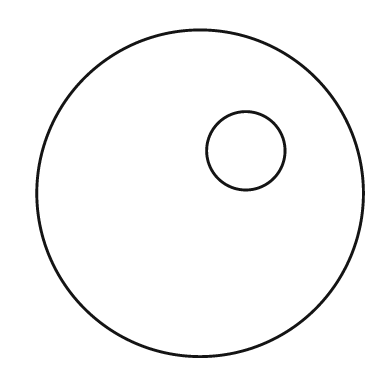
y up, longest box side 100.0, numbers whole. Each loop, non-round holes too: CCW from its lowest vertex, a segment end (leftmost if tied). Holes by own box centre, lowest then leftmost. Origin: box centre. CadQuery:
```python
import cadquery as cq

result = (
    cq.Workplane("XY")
    .moveTo(0.0, 0.0)
    .circle(50.0)
    .moveTo(14.0, 13.0)
    .circle(12.0)
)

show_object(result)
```